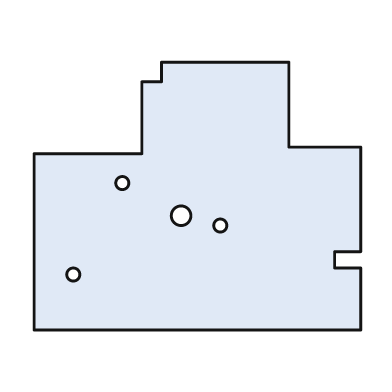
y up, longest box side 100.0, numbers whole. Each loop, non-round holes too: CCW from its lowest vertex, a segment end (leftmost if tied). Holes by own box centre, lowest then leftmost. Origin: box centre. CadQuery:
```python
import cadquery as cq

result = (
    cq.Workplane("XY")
    .moveTo(-50.0, -41.0)
    .lineTo(50.0, -41.0)
    .lineTo(50.0, -22.0)
    .lineTo(42.0, -22.0)
    .lineTo(42.0, -17.0)
    .lineTo(50.0, -17.0)
    .lineTo(50.0, 15.0)
    .lineTo(28.0, 15.0)
    .lineTo(28.0, 41.0)
    .lineTo(-11.0, 41.0)
    .lineTo(-11.0, 35.0)
    .lineTo(-17.0, 35.0)
    .lineTo(-17.0, 13.0)
    .lineTo(-50.0, 13.0)
    .close()
    .moveTo(-38.0, -24.0)
    .circle(2.0)
    .moveTo(7.0, -9.0)
    .circle(2.0)
    .moveTo(-5.0, -6.0)
    .circle(3.0)
    .moveTo(-23.0, 4.0)
    .circle(2.0)
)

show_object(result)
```